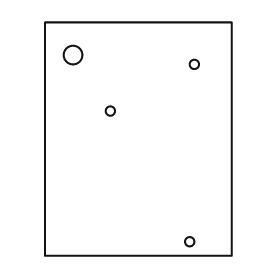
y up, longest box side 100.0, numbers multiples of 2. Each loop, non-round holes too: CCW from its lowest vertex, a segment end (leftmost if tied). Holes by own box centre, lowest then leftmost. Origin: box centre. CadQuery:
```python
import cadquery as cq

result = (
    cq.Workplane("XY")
    .moveTo(-40.0, -50.0)
    .lineTo(40.0, -50.0)
    .lineTo(40.0, 50.0)
    .lineTo(-40.0, 50.0)
    .close()
    .moveTo(22.0, -44.0)
    .circle(2.0)
    .moveTo(-12.0, 12.0)
    .circle(2.0)
    .moveTo(24.0, 32.0)
    .circle(2.0)
    .moveTo(-28.0, 36.0)
    .circle(4.0)
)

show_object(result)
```